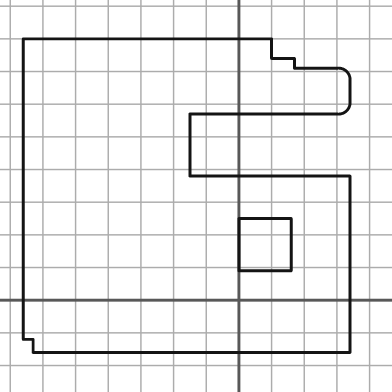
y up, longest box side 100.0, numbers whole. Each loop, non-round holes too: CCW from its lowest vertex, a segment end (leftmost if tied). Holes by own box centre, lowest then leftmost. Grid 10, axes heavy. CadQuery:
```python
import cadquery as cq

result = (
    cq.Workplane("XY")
    .moveTo(-63.0, -16.0)
    .lineTo(34.0, -16.0)
    .lineTo(34.0, 38.0)
    .lineTo(-15.0, 38.0)
    .lineTo(-15.0, 57.0)
    .lineTo(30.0, 57.0)
    .threePointArc((33.0, 58.0), (34.0, 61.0))
    .lineTo(34.0, 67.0)
    .threePointArc((33.0, 70.0), (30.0, 71.0))
    .lineTo(17.0, 71.0)
    .lineTo(17.0, 74.0)
    .lineTo(10.0, 74.0)
    .lineTo(10.0, 80.0)
    .lineTo(-66.0, 80.0)
    .lineTo(-66.0, -12.0)
    .lineTo(-63.0, -12.0)
    .close()
    .moveTo(0.0, 9.0)
    .lineTo(16.0, 9.0)
    .lineTo(16.0, 25.0)
    .lineTo(0.0, 25.0)
    .close()
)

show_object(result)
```